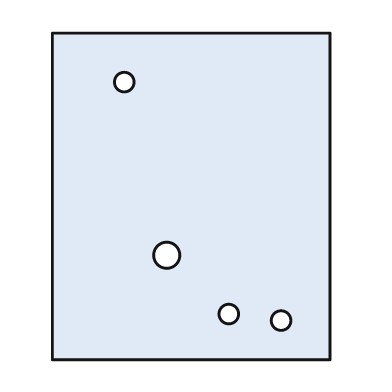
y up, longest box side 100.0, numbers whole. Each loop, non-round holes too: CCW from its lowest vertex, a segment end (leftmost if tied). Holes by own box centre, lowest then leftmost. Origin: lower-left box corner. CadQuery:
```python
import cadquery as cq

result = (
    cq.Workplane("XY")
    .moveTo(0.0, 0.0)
    .lineTo(85.0, 0.0)
    .lineTo(85.0, 100.0)
    .lineTo(0.0, 100.0)
    .close()
    .moveTo(70.0, 12.0)
    .circle(3.0)
    .moveTo(54.0, 14.0)
    .circle(3.0)
    .moveTo(35.0, 32.0)
    .circle(4.0)
    .moveTo(22.0, 85.0)
    .circle(3.0)
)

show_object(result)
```